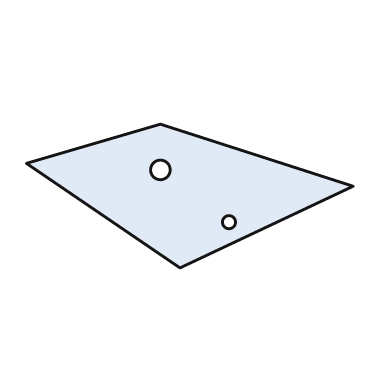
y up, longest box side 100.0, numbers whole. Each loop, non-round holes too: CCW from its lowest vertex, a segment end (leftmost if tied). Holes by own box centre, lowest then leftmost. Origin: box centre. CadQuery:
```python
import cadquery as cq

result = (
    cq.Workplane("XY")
    .moveTo(-3.0, -22.0)
    .lineTo(50.0, 3.0)
    .lineTo(-9.0, 22.0)
    .lineTo(-50.0, 10.0)
    .close()
    .moveTo(12.0, -8.0)
    .circle(2.0)
    .moveTo(-9.0, 8.0)
    .circle(3.0)
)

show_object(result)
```